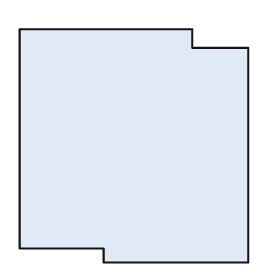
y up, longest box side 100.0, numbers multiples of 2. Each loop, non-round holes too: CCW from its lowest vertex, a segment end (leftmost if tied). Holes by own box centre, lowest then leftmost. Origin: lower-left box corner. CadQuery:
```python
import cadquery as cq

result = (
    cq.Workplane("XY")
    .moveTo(36.0, 0.0)
    .lineTo(98.0, 0.0)
    .lineTo(98.0, 92.0)
    .lineTo(74.0, 92.0)
    .lineTo(74.0, 100.0)
    .lineTo(0.0, 100.0)
    .lineTo(0.0, 6.0)
    .lineTo(36.0, 6.0)
    .close()
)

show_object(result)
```